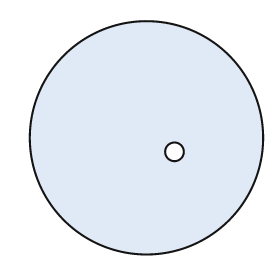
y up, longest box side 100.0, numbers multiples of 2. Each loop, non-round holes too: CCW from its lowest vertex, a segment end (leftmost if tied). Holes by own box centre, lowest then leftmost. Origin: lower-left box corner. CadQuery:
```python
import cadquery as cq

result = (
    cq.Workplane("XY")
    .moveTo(50.0, 50.0)
    .circle(50.0)
    .moveTo(62.0, 44.0)
    .circle(4.0)
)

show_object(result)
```